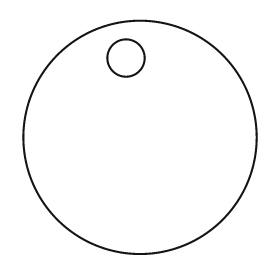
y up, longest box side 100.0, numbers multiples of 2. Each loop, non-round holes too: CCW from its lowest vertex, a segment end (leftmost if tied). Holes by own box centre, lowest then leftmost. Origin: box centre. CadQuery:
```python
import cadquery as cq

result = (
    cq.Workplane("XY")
    .moveTo(0.0, 0.0)
    .circle(50.0)
    .moveTo(-6.0, 34.0)
    .circle(8.0)
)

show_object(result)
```